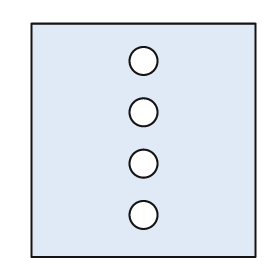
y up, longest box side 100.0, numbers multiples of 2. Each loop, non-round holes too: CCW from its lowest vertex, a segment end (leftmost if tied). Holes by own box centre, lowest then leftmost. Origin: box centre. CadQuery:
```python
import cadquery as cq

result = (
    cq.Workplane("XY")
    .moveTo(-48.0, -50.0)
    .lineTo(48.0, -50.0)
    .lineTo(48.0, 50.0)
    .lineTo(-48.0, 50.0)
    .close()
    .moveTo(0.0, -32.0)
    .circle(6.0)
    .moveTo(0.0, -10.0)
    .circle(6.0)
    .moveTo(0.0, 12.0)
    .circle(6.0)
    .moveTo(0.0, 34.0)
    .circle(6.0)
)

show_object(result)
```